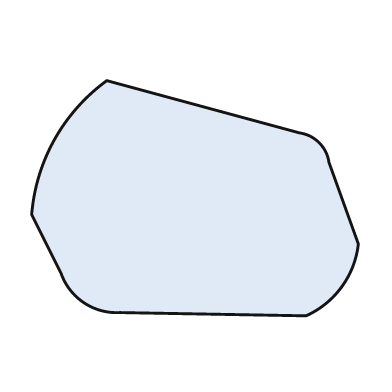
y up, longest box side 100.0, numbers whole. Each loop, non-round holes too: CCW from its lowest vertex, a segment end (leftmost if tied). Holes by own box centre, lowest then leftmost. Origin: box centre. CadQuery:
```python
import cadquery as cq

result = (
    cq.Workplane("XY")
    .moveTo(34.0, -36.0)
    .threePointArc((45.0, -27.0), (50.0, -14.0))
    .lineTo(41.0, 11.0)
    .threePointArc((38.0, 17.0), (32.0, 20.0))
    .lineTo(-27.0, 36.0)
    .threePointArc((-43.0, 18.0), (-50.0, -5.0))
    .lineTo(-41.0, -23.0)
    .threePointArc((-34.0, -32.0), (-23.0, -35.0))
    .close()
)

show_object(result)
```